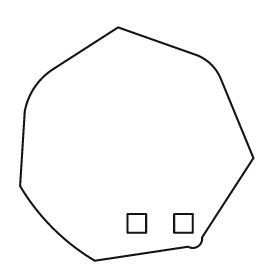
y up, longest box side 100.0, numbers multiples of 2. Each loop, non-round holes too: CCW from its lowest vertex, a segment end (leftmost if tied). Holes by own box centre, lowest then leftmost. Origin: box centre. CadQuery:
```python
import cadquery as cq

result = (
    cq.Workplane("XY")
    .moveTo(-18.0, -50.0)
    .lineTo(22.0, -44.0)
    .threePointArc((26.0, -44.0), (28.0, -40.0))
    .lineTo(50.0, -6.0)
    .lineTo(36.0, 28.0)
    .threePointArc((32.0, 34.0), (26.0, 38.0))
    .lineTo(-8.0, 50.0)
    .lineTo(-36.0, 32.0)
    .threePointArc((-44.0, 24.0), (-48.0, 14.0))
    .lineTo(-50.0, -18.0)
    .threePointArc((-36.0, -36.0), (-18.0, -50.0))
    .close()
    .moveTo(-4.0, -38.0)
    .lineTo(4.0, -38.0)
    .lineTo(4.0, -30.0)
    .lineTo(-4.0, -30.0)
    .close()
    .moveTo(16.0, -38.0)
    .lineTo(24.0, -38.0)
    .lineTo(24.0, -30.0)
    .lineTo(16.0, -30.0)
    .close()
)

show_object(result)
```